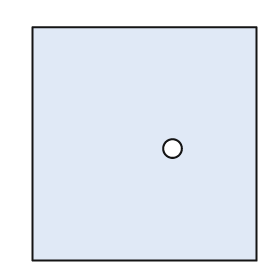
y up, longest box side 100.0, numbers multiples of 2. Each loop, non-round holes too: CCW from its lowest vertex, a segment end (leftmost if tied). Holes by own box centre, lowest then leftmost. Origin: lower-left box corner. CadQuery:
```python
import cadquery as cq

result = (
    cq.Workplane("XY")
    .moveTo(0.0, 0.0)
    .lineTo(96.0, 0.0)
    .lineTo(96.0, 100.0)
    .lineTo(0.0, 100.0)
    .close()
    .moveTo(60.0, 48.0)
    .circle(4.0)
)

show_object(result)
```